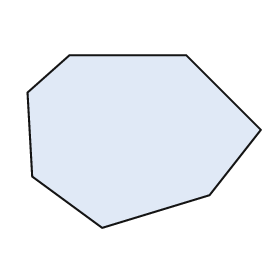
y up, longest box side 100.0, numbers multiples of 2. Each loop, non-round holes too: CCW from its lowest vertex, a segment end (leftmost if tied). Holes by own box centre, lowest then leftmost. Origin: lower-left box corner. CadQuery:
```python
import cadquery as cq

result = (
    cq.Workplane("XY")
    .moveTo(32.0, 0.0)
    .lineTo(78.0, 14.0)
    .lineTo(100.0, 42.0)
    .lineTo(68.0, 74.0)
    .lineTo(18.0, 74.0)
    .lineTo(0.0, 58.0)
    .lineTo(2.0, 22.0)
    .close()
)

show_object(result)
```